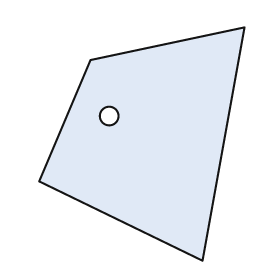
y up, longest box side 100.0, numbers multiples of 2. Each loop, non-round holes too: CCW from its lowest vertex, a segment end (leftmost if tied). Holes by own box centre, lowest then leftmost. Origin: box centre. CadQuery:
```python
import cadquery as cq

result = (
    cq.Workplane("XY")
    .moveTo(26.0, -50.0)
    .lineTo(44.0, 50.0)
    .lineTo(-22.0, 36.0)
    .lineTo(-44.0, -16.0)
    .close()
    .moveTo(-14.0, 12.0)
    .circle(4.0)
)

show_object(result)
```